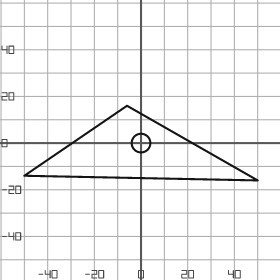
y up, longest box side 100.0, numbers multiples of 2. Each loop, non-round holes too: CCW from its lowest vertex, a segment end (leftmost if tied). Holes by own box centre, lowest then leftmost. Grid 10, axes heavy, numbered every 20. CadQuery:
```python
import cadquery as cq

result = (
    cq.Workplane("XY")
    .moveTo(50.0, -16.0)
    .lineTo(-6.0, 16.0)
    .lineTo(-50.0, -14.0)
    .close()
    .moveTo(0.0, 0.0)
    .circle(4.0)
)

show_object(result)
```